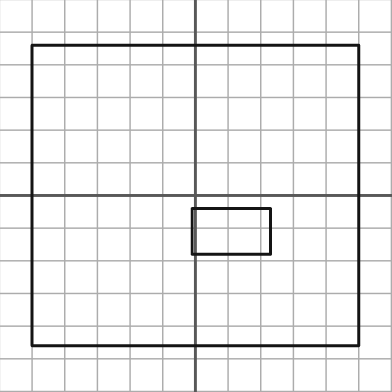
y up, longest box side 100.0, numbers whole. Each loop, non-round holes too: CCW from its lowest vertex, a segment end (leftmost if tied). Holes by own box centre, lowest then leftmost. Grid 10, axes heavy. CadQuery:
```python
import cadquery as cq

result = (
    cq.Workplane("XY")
    .moveTo(-50.0, -46.0)
    .lineTo(50.0, -46.0)
    .lineTo(50.0, 46.0)
    .lineTo(-50.0, 46.0)
    .close()
    .moveTo(-1.0, -18.0)
    .lineTo(23.0, -18.0)
    .lineTo(23.0, -4.0)
    .lineTo(-1.0, -4.0)
    .close()
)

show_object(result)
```